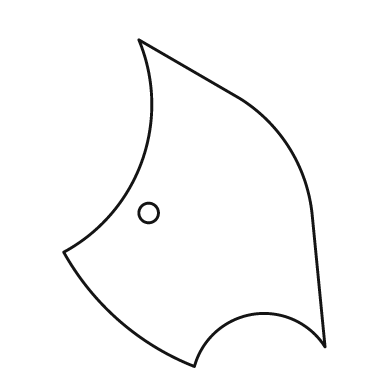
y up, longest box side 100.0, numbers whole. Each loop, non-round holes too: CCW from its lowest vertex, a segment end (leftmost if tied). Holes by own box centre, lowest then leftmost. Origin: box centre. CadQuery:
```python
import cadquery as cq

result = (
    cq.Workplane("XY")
    .moveTo(0.0, -50.0)
    .threePointArc((18.0, -34.0), (40.0, -44.0))
    .lineTo(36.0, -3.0)
    .threePointArc((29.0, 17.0), (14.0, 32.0))
    .lineTo(-17.0, 50.0)
    .threePointArc((-16.0, 13.0), (-40.0, -15.0))
    .threePointArc((-23.0, -36.0), (0.0, -50.0))
    .close()
    .moveTo(-14.0, -3.0)
    .circle(3.0)
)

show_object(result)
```